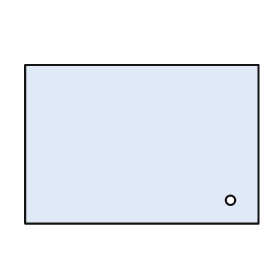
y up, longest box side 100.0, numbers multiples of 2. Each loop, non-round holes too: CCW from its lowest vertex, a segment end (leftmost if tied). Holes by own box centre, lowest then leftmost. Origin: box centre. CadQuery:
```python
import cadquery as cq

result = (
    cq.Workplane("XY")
    .moveTo(-50.0, -34.0)
    .lineTo(50.0, -34.0)
    .lineTo(50.0, 34.0)
    .lineTo(-50.0, 34.0)
    .close()
    .moveTo(38.0, -24.0)
    .circle(2.0)
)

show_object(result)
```